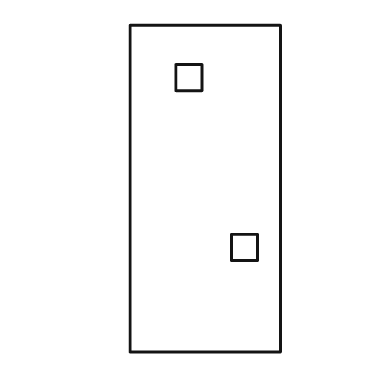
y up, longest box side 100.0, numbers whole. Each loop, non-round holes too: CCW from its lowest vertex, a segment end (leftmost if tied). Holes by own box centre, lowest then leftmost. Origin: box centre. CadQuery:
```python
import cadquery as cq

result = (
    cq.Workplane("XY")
    .moveTo(-23.0, -50.0)
    .lineTo(23.0, -50.0)
    .lineTo(23.0, 50.0)
    .lineTo(-23.0, 50.0)
    .close()
    .moveTo(8.0, -22.0)
    .lineTo(16.0, -22.0)
    .lineTo(16.0, -14.0)
    .lineTo(8.0, -14.0)
    .close()
    .moveTo(-9.0, 30.0)
    .lineTo(-1.0, 30.0)
    .lineTo(-1.0, 38.0)
    .lineTo(-9.0, 38.0)
    .close()
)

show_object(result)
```